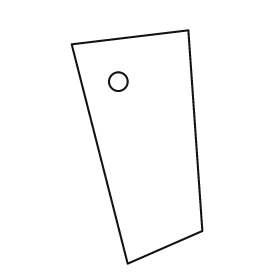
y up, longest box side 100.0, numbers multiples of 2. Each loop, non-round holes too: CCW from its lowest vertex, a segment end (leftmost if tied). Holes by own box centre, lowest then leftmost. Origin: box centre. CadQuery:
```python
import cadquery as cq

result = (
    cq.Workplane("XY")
    .moveTo(-4.0, -50.0)
    .lineTo(28.0, -36.0)
    .lineTo(22.0, 50.0)
    .lineTo(-28.0, 44.0)
    .close()
    .moveTo(-8.0, 28.0)
    .circle(4.0)
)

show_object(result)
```